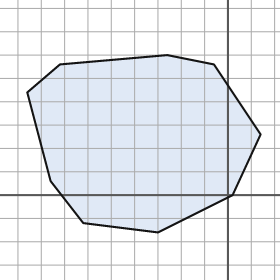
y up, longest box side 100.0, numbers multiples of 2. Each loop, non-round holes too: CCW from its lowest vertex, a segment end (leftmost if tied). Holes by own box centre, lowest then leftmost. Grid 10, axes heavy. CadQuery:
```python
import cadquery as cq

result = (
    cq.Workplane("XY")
    .moveTo(-30.0, -16.0)
    .lineTo(2.0, 0.0)
    .lineTo(14.0, 26.0)
    .lineTo(-6.0, 56.0)
    .lineTo(-26.0, 60.0)
    .lineTo(-72.0, 56.0)
    .lineTo(-86.0, 44.0)
    .lineTo(-76.0, 6.0)
    .lineTo(-62.0, -12.0)
    .close()
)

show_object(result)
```